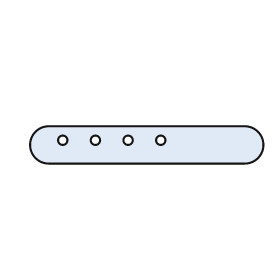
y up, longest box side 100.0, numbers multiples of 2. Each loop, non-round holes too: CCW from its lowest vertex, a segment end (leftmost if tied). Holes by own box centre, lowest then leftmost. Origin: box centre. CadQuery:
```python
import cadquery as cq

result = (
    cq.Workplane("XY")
    .moveTo(-42.0, -8.0)
    .lineTo(42.0, -8.0)
    .threePointArc((50.0, 0.0), (42.0, 8.0))
    .lineTo(-42.0, 8.0)
    .threePointArc((-50.0, 0.0), (-42.0, -8.0))
    .close()
    .moveTo(-36.0, 2.0)
    .circle(2.0)
    .moveTo(-22.0, 2.0)
    .circle(2.0)
    .moveTo(-8.0, 2.0)
    .circle(2.0)
    .moveTo(6.0, 2.0)
    .circle(2.0)
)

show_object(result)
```